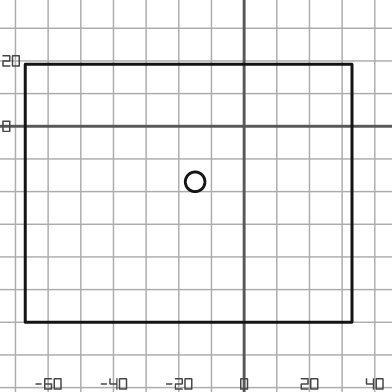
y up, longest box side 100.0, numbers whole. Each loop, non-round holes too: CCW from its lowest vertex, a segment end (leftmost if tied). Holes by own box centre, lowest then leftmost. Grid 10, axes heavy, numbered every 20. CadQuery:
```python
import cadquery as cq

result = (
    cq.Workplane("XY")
    .moveTo(-67.0, -60.0)
    .lineTo(33.0, -60.0)
    .lineTo(33.0, 19.0)
    .lineTo(-67.0, 19.0)
    .close()
    .moveTo(-15.0, -17.0)
    .circle(3.0)
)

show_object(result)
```